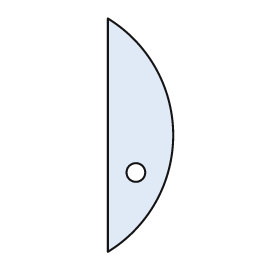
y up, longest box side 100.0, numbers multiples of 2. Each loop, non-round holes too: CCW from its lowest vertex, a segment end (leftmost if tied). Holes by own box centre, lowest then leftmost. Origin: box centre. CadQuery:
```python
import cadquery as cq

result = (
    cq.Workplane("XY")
    .moveTo(-14.0, -50.0)
    .threePointArc((14.0, 0.0), (-14.0, 50.0))
    .close()
    .moveTo(-2.0, -16.0)
    .circle(4.0)
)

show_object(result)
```